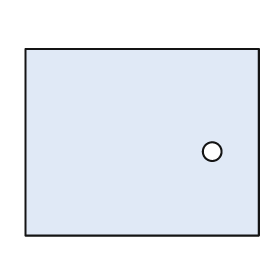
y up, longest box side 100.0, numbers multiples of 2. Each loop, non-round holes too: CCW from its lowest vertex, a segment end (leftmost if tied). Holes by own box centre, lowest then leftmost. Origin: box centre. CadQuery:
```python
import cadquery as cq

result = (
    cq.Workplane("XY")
    .moveTo(-50.0, -40.0)
    .lineTo(50.0, -40.0)
    .lineTo(50.0, 40.0)
    .lineTo(-50.0, 40.0)
    .close()
    .moveTo(30.0, -4.0)
    .circle(4.0)
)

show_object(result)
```